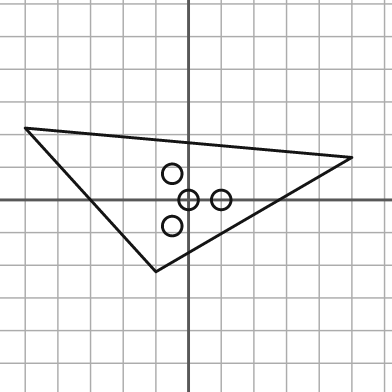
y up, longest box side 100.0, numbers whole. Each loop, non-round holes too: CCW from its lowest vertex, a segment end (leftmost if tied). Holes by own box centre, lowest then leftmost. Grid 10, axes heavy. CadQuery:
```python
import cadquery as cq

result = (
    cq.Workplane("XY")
    .moveTo(-10.0, -22.0)
    .lineTo(50.0, 13.0)
    .lineTo(-50.0, 22.0)
    .close()
    .moveTo(-5.0, -8.0)
    .circle(3.0)
    .moveTo(0.0, 0.0)
    .circle(3.0)
    .moveTo(10.0, 0.0)
    .circle(3.0)
    .moveTo(-5.0, 8.0)
    .circle(3.0)
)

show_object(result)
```